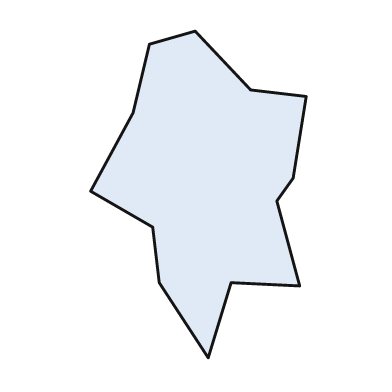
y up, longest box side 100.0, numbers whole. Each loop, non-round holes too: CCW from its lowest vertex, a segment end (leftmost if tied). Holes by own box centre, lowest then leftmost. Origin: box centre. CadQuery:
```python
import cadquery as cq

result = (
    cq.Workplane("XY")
    .moveTo(3.0, -50.0)
    .lineTo(10.0, -27.0)
    .lineTo(31.0, -28.0)
    .lineTo(24.0, -2.0)
    .lineTo(29.0, 5.0)
    .lineTo(33.0, 30.0)
    .lineTo(16.0, 32.0)
    .lineTo(-1.0, 50.0)
    .lineTo(-15.0, 46.0)
    .lineTo(-20.0, 25.0)
    .lineTo(-33.0, 1.0)
    .lineTo(-14.0, -10.0)
    .lineTo(-12.0, -27.0)
    .close()
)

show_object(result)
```